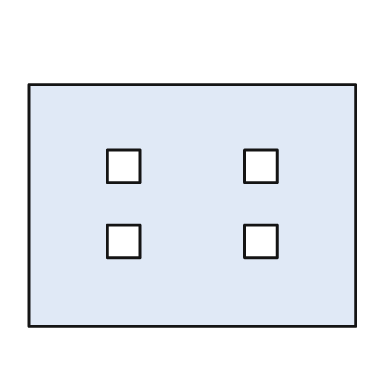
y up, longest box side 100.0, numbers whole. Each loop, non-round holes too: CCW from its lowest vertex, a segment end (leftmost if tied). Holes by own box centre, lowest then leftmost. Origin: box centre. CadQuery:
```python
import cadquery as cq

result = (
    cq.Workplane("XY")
    .moveTo(-50.0, -37.0)
    .lineTo(50.0, -37.0)
    .lineTo(50.0, 37.0)
    .lineTo(-50.0, 37.0)
    .close()
    .moveTo(-26.0, -16.0)
    .lineTo(-16.0, -16.0)
    .lineTo(-16.0, -6.0)
    .lineTo(-26.0, -6.0)
    .close()
    .moveTo(16.0, -16.0)
    .lineTo(26.0, -16.0)
    .lineTo(26.0, -6.0)
    .lineTo(16.0, -6.0)
    .close()
    .moveTo(-26.0, 7.0)
    .lineTo(-16.0, 7.0)
    .lineTo(-16.0, 17.0)
    .lineTo(-26.0, 17.0)
    .close()
    .moveTo(16.0, 7.0)
    .lineTo(26.0, 7.0)
    .lineTo(26.0, 17.0)
    .lineTo(16.0, 17.0)
    .close()
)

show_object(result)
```